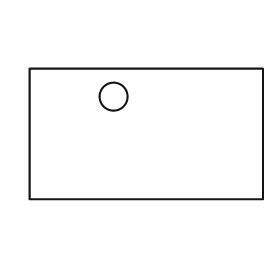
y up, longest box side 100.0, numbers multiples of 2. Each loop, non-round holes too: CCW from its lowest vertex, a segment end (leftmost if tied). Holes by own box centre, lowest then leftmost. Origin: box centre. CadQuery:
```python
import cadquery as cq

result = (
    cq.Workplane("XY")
    .moveTo(-50.0, -28.0)
    .lineTo(50.0, -28.0)
    .lineTo(50.0, 28.0)
    .lineTo(-50.0, 28.0)
    .close()
    .moveTo(-14.0, 16.0)
    .circle(6.0)
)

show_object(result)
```